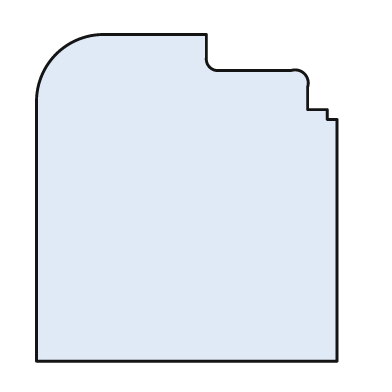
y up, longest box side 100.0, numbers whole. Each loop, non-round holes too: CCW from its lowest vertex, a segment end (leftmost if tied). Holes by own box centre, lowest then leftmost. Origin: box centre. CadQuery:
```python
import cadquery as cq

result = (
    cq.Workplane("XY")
    .moveTo(-46.0, -50.0)
    .lineTo(46.0, -50.0)
    .lineTo(46.0, 24.0)
    .lineTo(43.0, 24.0)
    .lineTo(43.0, 27.0)
    .lineTo(37.0, 27.0)
    .lineTo(37.0, 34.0)
    .threePointArc((36.0, 38.0), (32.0, 39.0))
    .lineTo(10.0, 39.0)
    .threePointArc((7.0, 40.0), (6.0, 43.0))
    .lineTo(6.0, 50.0)
    .lineTo(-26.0, 50.0)
    .threePointArc((-40.0, 44.0), (-46.0, 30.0))
    .close()
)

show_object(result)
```